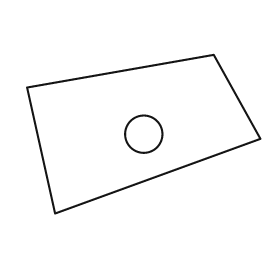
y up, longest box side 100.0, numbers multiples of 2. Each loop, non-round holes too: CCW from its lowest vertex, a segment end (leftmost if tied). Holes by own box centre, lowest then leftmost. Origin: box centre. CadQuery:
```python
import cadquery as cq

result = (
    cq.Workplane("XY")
    .moveTo(-38.0, -34.0)
    .lineTo(50.0, -2.0)
    .lineTo(30.0, 34.0)
    .lineTo(-50.0, 20.0)
    .close()
    .moveTo(0.0, 0.0)
    .circle(8.0)
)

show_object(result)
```